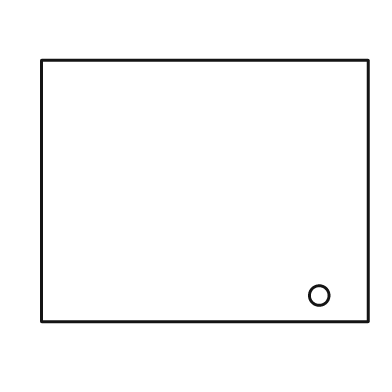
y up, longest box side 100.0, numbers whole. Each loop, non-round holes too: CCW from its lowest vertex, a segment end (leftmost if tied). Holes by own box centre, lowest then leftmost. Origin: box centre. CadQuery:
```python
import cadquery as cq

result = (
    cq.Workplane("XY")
    .moveTo(-50.0, -40.0)
    .lineTo(50.0, -40.0)
    .lineTo(50.0, 40.0)
    .lineTo(-50.0, 40.0)
    .close()
    .moveTo(35.0, -32.0)
    .circle(3.0)
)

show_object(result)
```